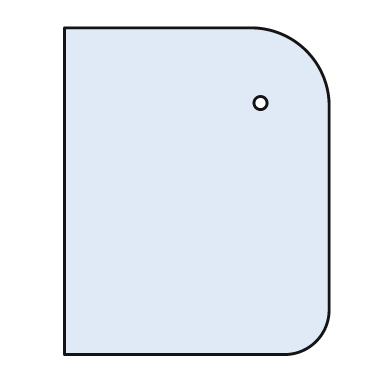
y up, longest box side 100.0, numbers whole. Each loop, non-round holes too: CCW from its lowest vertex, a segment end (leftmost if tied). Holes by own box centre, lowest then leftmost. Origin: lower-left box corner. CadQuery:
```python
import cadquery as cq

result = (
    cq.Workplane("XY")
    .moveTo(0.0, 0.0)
    .lineTo(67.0, 0.0)
    .threePointArc((77.0, 4.0), (81.0, 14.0))
    .lineTo(81.0, 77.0)
    .threePointArc((74.0, 93.0), (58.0, 100.0))
    .lineTo(0.0, 100.0)
    .close()
    .moveTo(60.0, 77.0)
    .circle(2.0)
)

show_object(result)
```